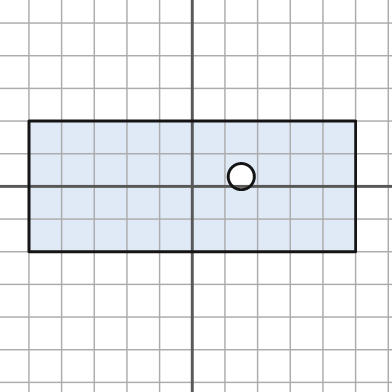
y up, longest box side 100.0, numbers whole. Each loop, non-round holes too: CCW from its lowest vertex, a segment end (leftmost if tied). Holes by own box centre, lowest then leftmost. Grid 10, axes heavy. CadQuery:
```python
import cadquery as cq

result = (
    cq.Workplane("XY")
    .moveTo(-50.0, -20.0)
    .lineTo(50.0, -20.0)
    .lineTo(50.0, 20.0)
    .lineTo(-50.0, 20.0)
    .close()
    .moveTo(15.0, 3.0)
    .circle(4.0)
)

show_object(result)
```